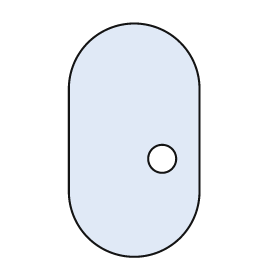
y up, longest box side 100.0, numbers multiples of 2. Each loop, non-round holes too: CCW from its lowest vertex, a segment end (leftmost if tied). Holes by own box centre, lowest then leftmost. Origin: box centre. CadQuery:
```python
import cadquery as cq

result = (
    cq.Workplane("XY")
    .moveTo(-28.0, -22.0)
    .threePointArc((0.0, -50.0), (28.0, -22.0))
    .lineTo(28.0, 22.0)
    .threePointArc((0.0, 50.0), (-28.0, 22.0))
    .close()
    .moveTo(12.0, -8.0)
    .circle(6.0)
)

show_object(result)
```